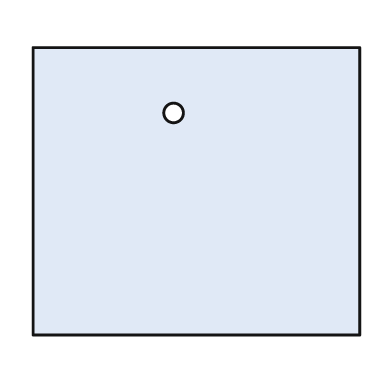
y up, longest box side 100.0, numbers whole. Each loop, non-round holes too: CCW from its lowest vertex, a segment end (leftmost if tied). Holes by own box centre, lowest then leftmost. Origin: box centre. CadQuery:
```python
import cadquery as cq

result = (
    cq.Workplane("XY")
    .moveTo(-50.0, -44.0)
    .lineTo(50.0, -44.0)
    .lineTo(50.0, 44.0)
    .lineTo(-50.0, 44.0)
    .close()
    .moveTo(-7.0, 24.0)
    .circle(3.0)
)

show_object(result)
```